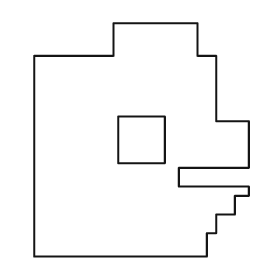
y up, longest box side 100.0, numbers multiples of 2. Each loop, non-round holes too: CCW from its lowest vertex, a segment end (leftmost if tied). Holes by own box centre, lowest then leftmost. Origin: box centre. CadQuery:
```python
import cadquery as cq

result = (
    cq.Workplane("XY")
    .moveTo(-46.0, -50.0)
    .lineTo(28.0, -50.0)
    .lineTo(28.0, -40.0)
    .lineTo(32.0, -40.0)
    .lineTo(32.0, -32.0)
    .lineTo(40.0, -32.0)
    .lineTo(40.0, -24.0)
    .lineTo(46.0, -24.0)
    .lineTo(46.0, -20.0)
    .lineTo(16.0, -20.0)
    .lineTo(16.0, -12.0)
    .lineTo(46.0, -12.0)
    .lineTo(46.0, 8.0)
    .lineTo(32.0, 8.0)
    .lineTo(32.0, 36.0)
    .lineTo(24.0, 36.0)
    .lineTo(24.0, 50.0)
    .lineTo(-12.0, 50.0)
    .lineTo(-12.0, 36.0)
    .lineTo(-46.0, 36.0)
    .close()
    .moveTo(-10.0, -10.0)
    .lineTo(10.0, -10.0)
    .lineTo(10.0, 10.0)
    .lineTo(-10.0, 10.0)
    .close()
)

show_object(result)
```